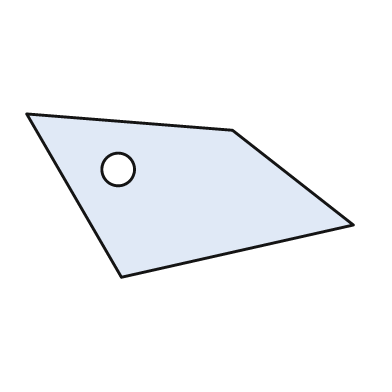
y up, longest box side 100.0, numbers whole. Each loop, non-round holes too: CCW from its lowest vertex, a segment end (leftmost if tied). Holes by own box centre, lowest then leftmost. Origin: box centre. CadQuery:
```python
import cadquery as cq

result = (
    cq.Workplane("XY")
    .moveTo(-21.0, -25.0)
    .lineTo(50.0, -9.0)
    .lineTo(13.0, 20.0)
    .lineTo(-50.0, 25.0)
    .close()
    .moveTo(-22.0, 8.0)
    .circle(5.0)
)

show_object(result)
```